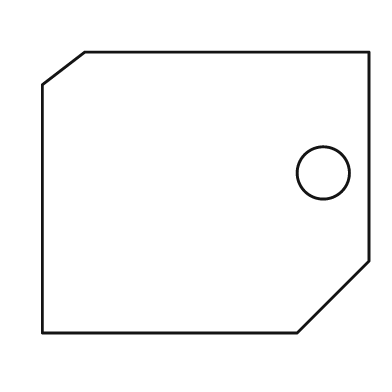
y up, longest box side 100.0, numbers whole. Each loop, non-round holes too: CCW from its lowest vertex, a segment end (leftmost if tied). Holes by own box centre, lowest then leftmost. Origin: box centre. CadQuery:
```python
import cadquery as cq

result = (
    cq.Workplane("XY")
    .moveTo(-50.0, -43.0)
    .lineTo(28.0, -43.0)
    .lineTo(50.0, -21.0)
    .lineTo(50.0, 43.0)
    .lineTo(-37.0, 43.0)
    .lineTo(-50.0, 33.0)
    .close()
    .moveTo(36.0, 6.0)
    .circle(8.0)
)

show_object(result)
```